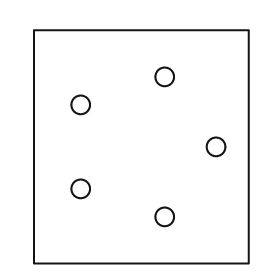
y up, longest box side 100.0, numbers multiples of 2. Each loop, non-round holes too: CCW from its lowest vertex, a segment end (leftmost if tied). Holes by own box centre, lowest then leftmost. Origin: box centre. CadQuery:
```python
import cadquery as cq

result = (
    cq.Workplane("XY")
    .moveTo(-46.0, -50.0)
    .lineTo(46.0, -50.0)
    .lineTo(46.0, 50.0)
    .lineTo(-46.0, 50.0)
    .close()
    .moveTo(10.0, -30.0)
    .circle(4.0)
    .moveTo(-26.0, -18.0)
    .circle(4.0)
    .moveTo(32.0, 0.0)
    .circle(4.0)
    .moveTo(-26.0, 18.0)
    .circle(4.0)
    .moveTo(10.0, 30.0)
    .circle(4.0)
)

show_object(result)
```